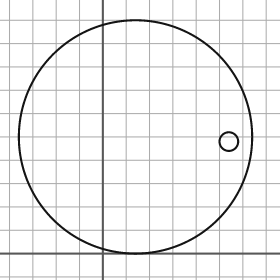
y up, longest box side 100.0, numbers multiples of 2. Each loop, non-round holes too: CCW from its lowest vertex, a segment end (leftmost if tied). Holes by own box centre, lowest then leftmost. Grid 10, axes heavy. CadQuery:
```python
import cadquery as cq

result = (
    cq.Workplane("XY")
    .moveTo(14.0, 50.0)
    .circle(50.0)
    .moveTo(54.0, 48.0)
    .circle(4.0)
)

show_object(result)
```